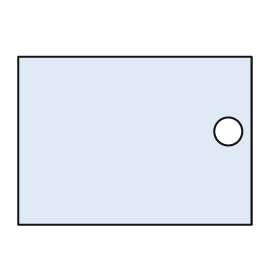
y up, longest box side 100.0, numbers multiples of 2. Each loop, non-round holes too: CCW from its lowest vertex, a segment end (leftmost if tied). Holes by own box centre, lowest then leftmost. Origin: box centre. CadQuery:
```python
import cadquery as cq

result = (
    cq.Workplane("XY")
    .moveTo(-50.0, -36.0)
    .lineTo(50.0, -36.0)
    .lineTo(50.0, 36.0)
    .lineTo(-50.0, 36.0)
    .close()
    .moveTo(40.0, 4.0)
    .circle(6.0)
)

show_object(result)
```